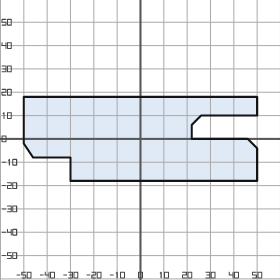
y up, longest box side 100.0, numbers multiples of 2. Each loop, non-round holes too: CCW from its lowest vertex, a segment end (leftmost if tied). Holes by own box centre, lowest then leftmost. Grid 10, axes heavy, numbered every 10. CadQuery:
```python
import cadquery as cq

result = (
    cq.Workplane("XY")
    .moveTo(-30.0, -18.0)
    .lineTo(50.0, -18.0)
    .lineTo(50.0, -4.0)
    .lineTo(46.0, 0.0)
    .lineTo(22.0, 0.0)
    .lineTo(22.0, 6.0)
    .lineTo(26.0, 10.0)
    .lineTo(50.0, 10.0)
    .lineTo(50.0, 18.0)
    .lineTo(-50.0, 18.0)
    .lineTo(-50.0, -2.0)
    .lineTo(-46.0, -8.0)
    .lineTo(-30.0, -8.0)
    .close()
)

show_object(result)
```